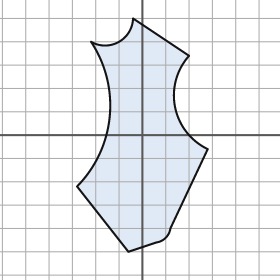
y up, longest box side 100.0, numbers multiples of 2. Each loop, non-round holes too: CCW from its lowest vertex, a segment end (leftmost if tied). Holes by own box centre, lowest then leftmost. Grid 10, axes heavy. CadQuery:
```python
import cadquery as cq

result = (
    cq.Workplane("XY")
    .moveTo(-6.0, -50.0)
    .lineTo(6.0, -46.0)
    .threePointArc((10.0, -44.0), (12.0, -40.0))
    .lineTo(28.0, -6.0)
    .threePointArc((14.0, 12.0), (20.0, 34.0))
    .lineTo(-4.0, 50.0)
    .threePointArc((-10.0, 40.0), (-22.0, 40.0))
    .threePointArc((-14.0, 8.0), (-28.0, -22.0))
    .close()
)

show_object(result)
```